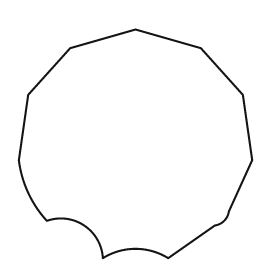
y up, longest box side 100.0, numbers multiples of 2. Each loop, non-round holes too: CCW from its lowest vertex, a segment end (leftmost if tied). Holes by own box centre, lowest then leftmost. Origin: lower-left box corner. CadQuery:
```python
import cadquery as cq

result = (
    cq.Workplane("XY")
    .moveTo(36.0, 0.0)
    .threePointArc((50.0, 4.0), (64.0, 0.0))
    .lineTo(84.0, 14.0)
    .threePointArc((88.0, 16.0), (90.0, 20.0))
    .lineTo(100.0, 42.0)
    .lineTo(96.0, 70.0)
    .lineTo(78.0, 90.0)
    .lineTo(50.0, 98.0)
    .lineTo(22.0, 90.0)
    .lineTo(4.0, 70.0)
    .lineTo(0.0, 42.0)
    .threePointArc((4.0, 28.0), (12.0, 16.0))
    .threePointArc((28.0, 14.0), (36.0, 0.0))
    .close()
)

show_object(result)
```